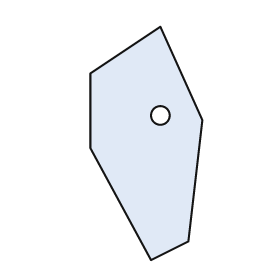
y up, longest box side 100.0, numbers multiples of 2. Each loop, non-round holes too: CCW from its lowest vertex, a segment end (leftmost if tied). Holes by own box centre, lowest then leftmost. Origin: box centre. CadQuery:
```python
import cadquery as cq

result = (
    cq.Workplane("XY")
    .moveTo(2.0, -50.0)
    .lineTo(18.0, -42.0)
    .lineTo(24.0, 10.0)
    .lineTo(6.0, 50.0)
    .lineTo(-24.0, 30.0)
    .lineTo(-24.0, -2.0)
    .close()
    .moveTo(6.0, 12.0)
    .circle(4.0)
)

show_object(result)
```